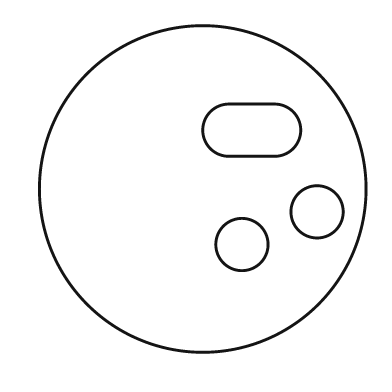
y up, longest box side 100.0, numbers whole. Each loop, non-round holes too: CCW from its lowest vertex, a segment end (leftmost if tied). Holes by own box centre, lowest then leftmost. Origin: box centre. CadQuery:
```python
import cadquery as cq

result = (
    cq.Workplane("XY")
    .moveTo(0.0, 0.0)
    .circle(50.0)
    .moveTo(12.0, -17.0)
    .circle(8.0)
    .moveTo(35.0, -7.0)
    .circle(8.0)
    .moveTo(8.0, 10.0)
    .lineTo(22.0, 10.0)
    .threePointArc((30.0, 18.0), (22.0, 26.0))
    .lineTo(8.0, 26.0)
    .threePointArc((0.0, 18.0), (8.0, 10.0))
    .close()
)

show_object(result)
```